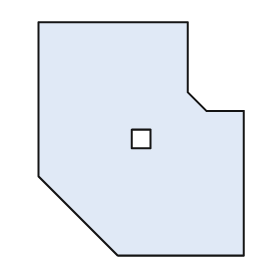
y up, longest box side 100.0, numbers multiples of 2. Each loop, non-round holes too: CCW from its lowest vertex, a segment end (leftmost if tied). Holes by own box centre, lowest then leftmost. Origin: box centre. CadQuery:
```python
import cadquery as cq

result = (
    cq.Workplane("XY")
    .moveTo(-10.0, -50.0)
    .lineTo(44.0, -50.0)
    .lineTo(44.0, 12.0)
    .lineTo(28.0, 12.0)
    .lineTo(20.0, 20.0)
    .lineTo(20.0, 50.0)
    .lineTo(-44.0, 50.0)
    .lineTo(-44.0, -16.0)
    .close()
    .moveTo(-4.0, -4.0)
    .lineTo(4.0, -4.0)
    .lineTo(4.0, 4.0)
    .lineTo(-4.0, 4.0)
    .close()
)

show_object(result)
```